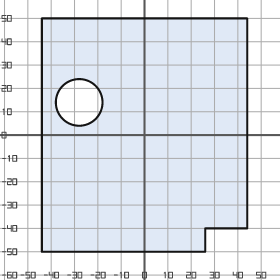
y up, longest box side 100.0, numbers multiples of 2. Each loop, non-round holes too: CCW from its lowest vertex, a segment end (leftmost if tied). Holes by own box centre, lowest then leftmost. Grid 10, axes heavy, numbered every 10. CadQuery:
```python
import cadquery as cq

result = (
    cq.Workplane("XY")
    .moveTo(-44.0, -50.0)
    .lineTo(26.0, -50.0)
    .lineTo(26.0, -40.0)
    .lineTo(44.0, -40.0)
    .lineTo(44.0, 50.0)
    .lineTo(-44.0, 50.0)
    .close()
    .moveTo(-28.0, 14.0)
    .circle(10.0)
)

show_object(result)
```